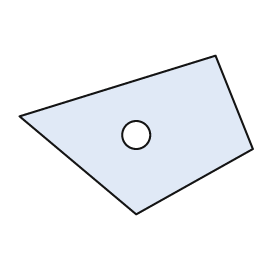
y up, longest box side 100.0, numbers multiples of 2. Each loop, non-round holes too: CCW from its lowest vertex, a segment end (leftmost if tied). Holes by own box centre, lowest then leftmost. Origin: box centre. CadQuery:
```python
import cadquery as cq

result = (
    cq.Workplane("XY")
    .moveTo(0.0, -34.0)
    .lineTo(50.0, -6.0)
    .lineTo(34.0, 34.0)
    .lineTo(-50.0, 8.0)
    .close()
    .moveTo(0.0, 0.0)
    .circle(6.0)
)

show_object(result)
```